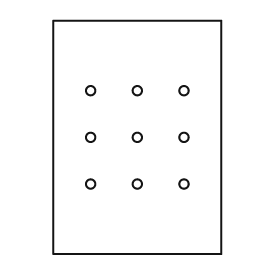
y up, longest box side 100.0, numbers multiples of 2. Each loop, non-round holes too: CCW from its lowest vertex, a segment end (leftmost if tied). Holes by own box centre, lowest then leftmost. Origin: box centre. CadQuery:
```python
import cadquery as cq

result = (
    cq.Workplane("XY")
    .moveTo(-36.0, -50.0)
    .lineTo(36.0, -50.0)
    .lineTo(36.0, 50.0)
    .lineTo(-36.0, 50.0)
    .close()
    .moveTo(-20.0, -20.0)
    .circle(2.0)
    .moveTo(0.0, -20.0)
    .circle(2.0)
    .moveTo(20.0, -20.0)
    .circle(2.0)
    .moveTo(-20.0, 0.0)
    .circle(2.0)
    .moveTo(0.0, 0.0)
    .circle(2.0)
    .moveTo(20.0, 0.0)
    .circle(2.0)
    .moveTo(-20.0, 20.0)
    .circle(2.0)
    .moveTo(0.0, 20.0)
    .circle(2.0)
    .moveTo(20.0, 20.0)
    .circle(2.0)
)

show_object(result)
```